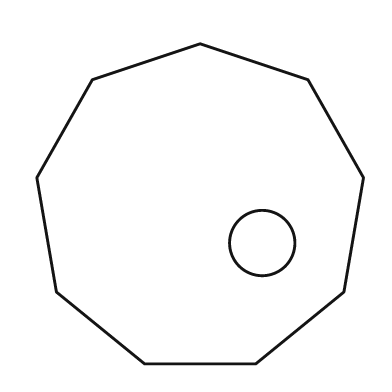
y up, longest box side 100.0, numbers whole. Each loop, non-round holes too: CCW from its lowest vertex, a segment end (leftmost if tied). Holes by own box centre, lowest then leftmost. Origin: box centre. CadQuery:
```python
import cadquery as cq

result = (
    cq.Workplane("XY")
    .moveTo(-17.0, -49.0)
    .lineTo(17.0, -49.0)
    .lineTo(44.0, -27.0)
    .lineTo(50.0, 8.0)
    .lineTo(33.0, 38.0)
    .lineTo(0.0, 49.0)
    .lineTo(-33.0, 38.0)
    .lineTo(-50.0, 8.0)
    .lineTo(-44.0, -27.0)
    .close()
    .moveTo(19.0, -12.0)
    .circle(10.0)
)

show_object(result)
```